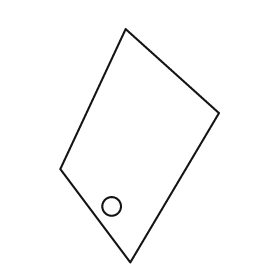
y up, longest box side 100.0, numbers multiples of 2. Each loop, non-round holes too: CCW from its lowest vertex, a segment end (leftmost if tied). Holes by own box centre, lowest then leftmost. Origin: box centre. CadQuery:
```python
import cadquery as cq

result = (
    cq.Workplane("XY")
    .moveTo(-4.0, -50.0)
    .lineTo(34.0, 14.0)
    .lineTo(-6.0, 50.0)
    .lineTo(-34.0, -10.0)
    .close()
    .moveTo(-12.0, -26.0)
    .circle(4.0)
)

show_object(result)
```